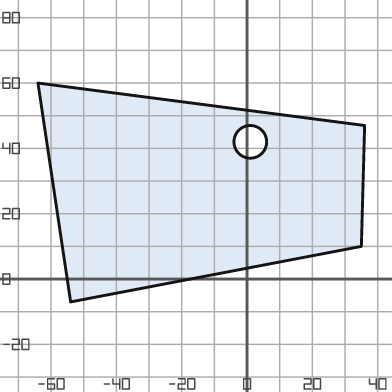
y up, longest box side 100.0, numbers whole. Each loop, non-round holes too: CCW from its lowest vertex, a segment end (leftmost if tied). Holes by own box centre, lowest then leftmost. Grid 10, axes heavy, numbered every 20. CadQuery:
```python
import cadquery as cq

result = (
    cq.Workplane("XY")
    .moveTo(-54.0, -7.0)
    .lineTo(35.0, 10.0)
    .lineTo(36.0, 47.0)
    .lineTo(-64.0, 60.0)
    .close()
    .moveTo(1.0, 42.0)
    .circle(5.0)
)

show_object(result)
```